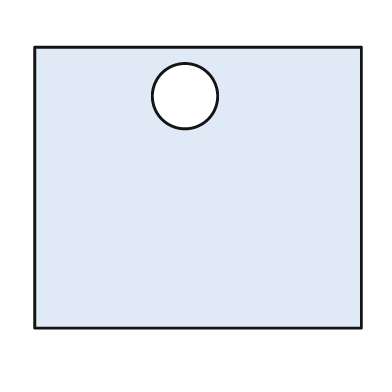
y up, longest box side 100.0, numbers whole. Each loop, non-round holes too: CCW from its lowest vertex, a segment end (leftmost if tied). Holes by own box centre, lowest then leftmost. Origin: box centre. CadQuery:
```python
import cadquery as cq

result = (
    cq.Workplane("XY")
    .moveTo(-50.0, -43.0)
    .lineTo(50.0, -43.0)
    .lineTo(50.0, 43.0)
    .lineTo(-50.0, 43.0)
    .close()
    .moveTo(-4.0, 28.0)
    .circle(10.0)
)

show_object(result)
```